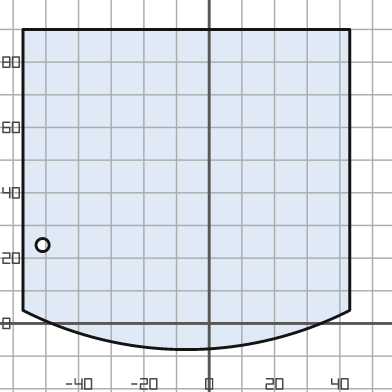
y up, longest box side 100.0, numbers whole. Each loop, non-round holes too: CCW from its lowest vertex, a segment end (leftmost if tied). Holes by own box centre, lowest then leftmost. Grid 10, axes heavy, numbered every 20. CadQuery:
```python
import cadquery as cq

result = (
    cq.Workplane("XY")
    .moveTo(-57.0, 4.0)
    .threePointArc((-7.0, -8.0), (43.0, 4.0))
    .lineTo(43.0, 90.0)
    .lineTo(-57.0, 90.0)
    .close()
    .moveTo(-51.0, 24.0)
    .circle(2.0)
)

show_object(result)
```